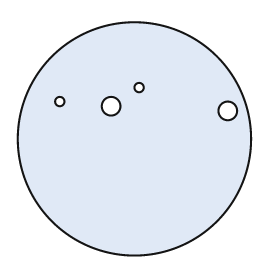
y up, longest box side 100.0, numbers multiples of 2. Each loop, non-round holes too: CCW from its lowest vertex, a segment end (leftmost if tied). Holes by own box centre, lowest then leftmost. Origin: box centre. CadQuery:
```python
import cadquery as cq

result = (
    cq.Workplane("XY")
    .moveTo(0.0, 0.0)
    .circle(50.0)
    .moveTo(40.0, 12.0)
    .circle(4.0)
    .moveTo(-10.0, 14.0)
    .circle(4.0)
    .moveTo(-32.0, 16.0)
    .circle(2.0)
    .moveTo(2.0, 22.0)
    .circle(2.0)
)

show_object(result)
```